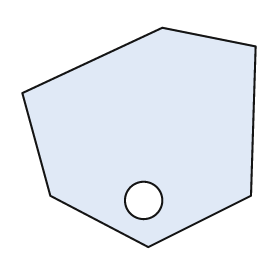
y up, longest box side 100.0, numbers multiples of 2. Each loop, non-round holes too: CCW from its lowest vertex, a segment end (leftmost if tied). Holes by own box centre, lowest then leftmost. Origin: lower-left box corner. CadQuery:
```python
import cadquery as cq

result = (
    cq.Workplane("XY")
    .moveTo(54.0, 0.0)
    .lineTo(98.0, 22.0)
    .lineTo(100.0, 86.0)
    .lineTo(60.0, 94.0)
    .lineTo(0.0, 66.0)
    .lineTo(12.0, 22.0)
    .close()
    .moveTo(52.0, 20.0)
    .circle(8.0)
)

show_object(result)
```